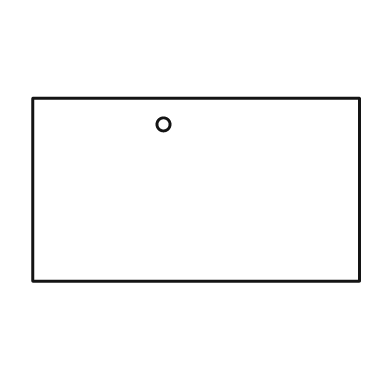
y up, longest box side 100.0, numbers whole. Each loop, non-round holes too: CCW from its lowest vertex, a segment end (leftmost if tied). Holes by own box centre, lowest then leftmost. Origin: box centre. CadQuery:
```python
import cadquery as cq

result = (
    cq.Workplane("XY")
    .moveTo(-50.0, -28.0)
    .lineTo(50.0, -28.0)
    .lineTo(50.0, 28.0)
    .lineTo(-50.0, 28.0)
    .close()
    .moveTo(-10.0, 20.0)
    .circle(2.0)
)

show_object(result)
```